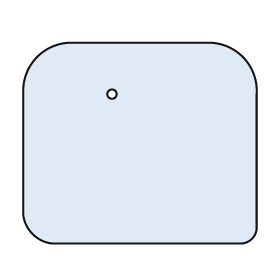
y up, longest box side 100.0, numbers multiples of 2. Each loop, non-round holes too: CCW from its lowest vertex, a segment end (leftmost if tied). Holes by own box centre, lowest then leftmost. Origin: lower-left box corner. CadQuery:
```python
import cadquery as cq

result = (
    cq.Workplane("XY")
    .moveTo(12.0, 0.0)
    .lineTo(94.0, 0.0)
    .threePointArc((98.0, 2.0), (100.0, 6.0))
    .lineTo(100.0, 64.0)
    .threePointArc((94.0, 80.0), (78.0, 86.0))
    .lineTo(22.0, 86.0)
    .threePointArc((6.0, 80.0), (0.0, 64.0))
    .lineTo(0.0, 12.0)
    .threePointArc((4.0, 4.0), (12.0, 0.0))
    .close()
    .moveTo(38.0, 64.0)
    .circle(2.0)
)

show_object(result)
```